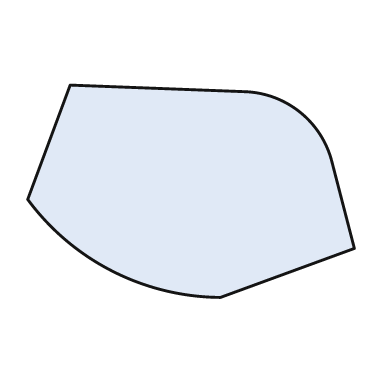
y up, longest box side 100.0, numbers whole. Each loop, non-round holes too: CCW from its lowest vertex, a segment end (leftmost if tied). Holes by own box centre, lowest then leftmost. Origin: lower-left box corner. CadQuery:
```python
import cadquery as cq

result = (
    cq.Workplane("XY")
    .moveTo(59.0, 0.0)
    .lineTo(100.0, 15.0)
    .lineTo(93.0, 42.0)
    .threePointArc((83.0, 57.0), (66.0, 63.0))
    .lineTo(13.0, 65.0)
    .lineTo(0.0, 30.0)
    .threePointArc((26.0, 8.0), (59.0, 0.0))
    .close()
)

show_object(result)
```